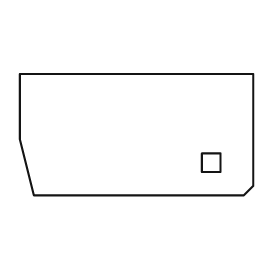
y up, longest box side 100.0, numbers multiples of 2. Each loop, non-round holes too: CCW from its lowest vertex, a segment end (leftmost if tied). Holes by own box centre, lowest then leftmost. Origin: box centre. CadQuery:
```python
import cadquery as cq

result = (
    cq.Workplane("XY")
    .moveTo(-44.0, -26.0)
    .lineTo(46.0, -26.0)
    .lineTo(50.0, -22.0)
    .lineTo(50.0, 26.0)
    .lineTo(-50.0, 26.0)
    .lineTo(-50.0, -2.0)
    .close()
    .moveTo(28.0, -16.0)
    .lineTo(36.0, -16.0)
    .lineTo(36.0, -8.0)
    .lineTo(28.0, -8.0)
    .close()
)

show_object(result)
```